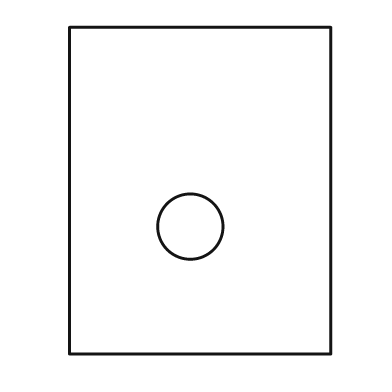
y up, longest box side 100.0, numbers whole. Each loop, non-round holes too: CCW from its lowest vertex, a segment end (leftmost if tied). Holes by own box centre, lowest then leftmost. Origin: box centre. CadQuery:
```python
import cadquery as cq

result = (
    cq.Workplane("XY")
    .moveTo(-40.0, -50.0)
    .lineTo(40.0, -50.0)
    .lineTo(40.0, 50.0)
    .lineTo(-40.0, 50.0)
    .close()
    .moveTo(-3.0, -11.0)
    .circle(10.0)
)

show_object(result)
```